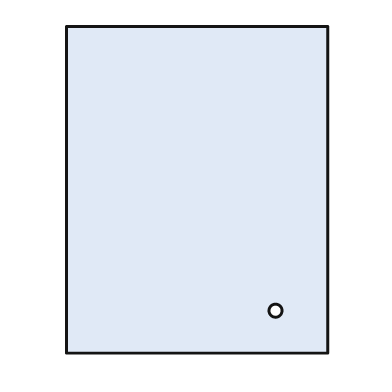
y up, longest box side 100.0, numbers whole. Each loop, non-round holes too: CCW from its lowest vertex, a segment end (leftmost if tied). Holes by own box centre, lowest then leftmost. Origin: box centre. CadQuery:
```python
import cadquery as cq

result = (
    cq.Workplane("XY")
    .moveTo(-40.0, -50.0)
    .lineTo(40.0, -50.0)
    .lineTo(40.0, 50.0)
    .lineTo(-40.0, 50.0)
    .close()
    .moveTo(24.0, -37.0)
    .circle(2.0)
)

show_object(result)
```